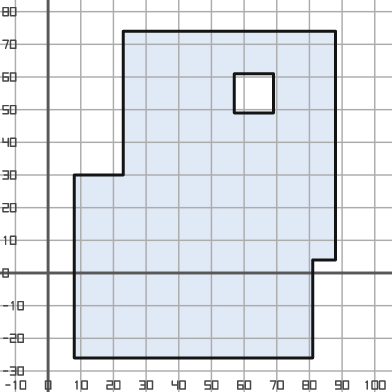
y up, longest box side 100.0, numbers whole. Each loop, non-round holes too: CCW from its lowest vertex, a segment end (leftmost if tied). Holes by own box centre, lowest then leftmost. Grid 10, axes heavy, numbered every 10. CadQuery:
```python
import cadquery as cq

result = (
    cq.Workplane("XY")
    .moveTo(8.0, -26.0)
    .lineTo(81.0, -26.0)
    .lineTo(81.0, 4.0)
    .lineTo(88.0, 4.0)
    .lineTo(88.0, 74.0)
    .lineTo(23.0, 74.0)
    .lineTo(23.0, 30.0)
    .lineTo(8.0, 30.0)
    .close()
    .moveTo(57.0, 49.0)
    .lineTo(69.0, 49.0)
    .lineTo(69.0, 61.0)
    .lineTo(57.0, 61.0)
    .close()
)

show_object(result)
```